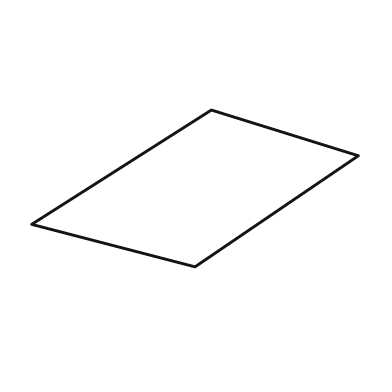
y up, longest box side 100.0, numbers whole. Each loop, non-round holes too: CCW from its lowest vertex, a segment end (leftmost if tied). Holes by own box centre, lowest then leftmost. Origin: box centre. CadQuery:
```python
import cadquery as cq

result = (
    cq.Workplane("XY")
    .moveTo(0.0, -24.0)
    .lineTo(50.0, 10.0)
    .lineTo(5.0, 24.0)
    .lineTo(-50.0, -11.0)
    .close()
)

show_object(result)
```